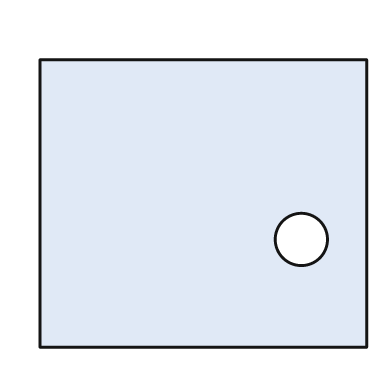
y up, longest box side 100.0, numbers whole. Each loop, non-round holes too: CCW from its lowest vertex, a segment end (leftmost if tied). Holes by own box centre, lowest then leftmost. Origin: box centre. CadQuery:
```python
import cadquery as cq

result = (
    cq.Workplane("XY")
    .moveTo(-50.0, -44.0)
    .lineTo(50.0, -44.0)
    .lineTo(50.0, 44.0)
    .lineTo(-50.0, 44.0)
    .close()
    .moveTo(30.0, -11.0)
    .circle(8.0)
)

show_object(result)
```